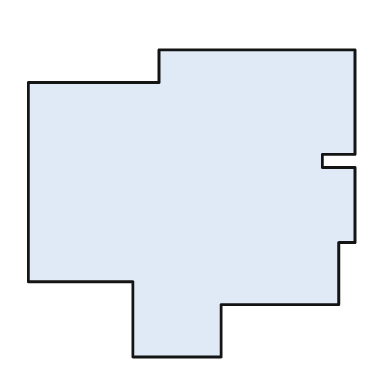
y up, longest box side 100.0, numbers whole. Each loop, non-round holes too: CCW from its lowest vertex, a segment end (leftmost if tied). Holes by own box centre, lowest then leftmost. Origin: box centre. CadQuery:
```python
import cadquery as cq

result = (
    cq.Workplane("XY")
    .moveTo(-18.0, -47.0)
    .lineTo(9.0, -47.0)
    .lineTo(9.0, -31.0)
    .lineTo(45.0, -31.0)
    .lineTo(45.0, -12.0)
    .lineTo(50.0, -12.0)
    .lineTo(50.0, 11.0)
    .lineTo(40.0, 11.0)
    .lineTo(40.0, 15.0)
    .lineTo(50.0, 15.0)
    .lineTo(50.0, 47.0)
    .lineTo(-10.0, 47.0)
    .lineTo(-10.0, 37.0)
    .lineTo(-50.0, 37.0)
    .lineTo(-50.0, -24.0)
    .lineTo(-18.0, -24.0)
    .close()
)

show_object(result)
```